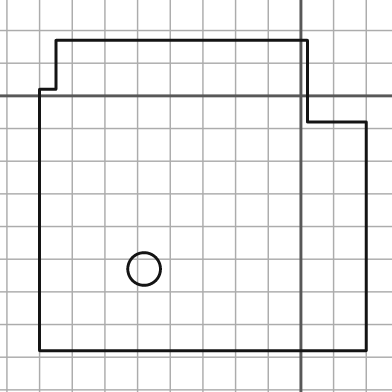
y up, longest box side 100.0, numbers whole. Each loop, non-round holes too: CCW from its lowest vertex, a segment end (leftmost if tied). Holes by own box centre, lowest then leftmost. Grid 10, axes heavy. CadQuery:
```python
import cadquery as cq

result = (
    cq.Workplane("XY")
    .moveTo(-80.0, -78.0)
    .lineTo(20.0, -78.0)
    .lineTo(20.0, -8.0)
    .lineTo(2.0, -8.0)
    .lineTo(2.0, 17.0)
    .lineTo(-75.0, 17.0)
    .lineTo(-75.0, 2.0)
    .lineTo(-80.0, 2.0)
    .close()
    .moveTo(-48.0, -53.0)
    .circle(5.0)
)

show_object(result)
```